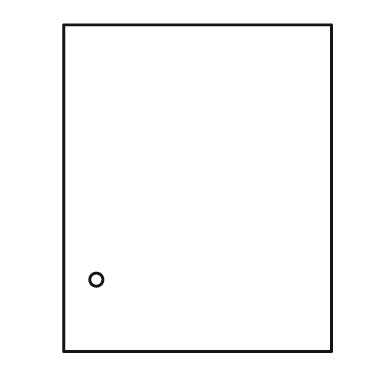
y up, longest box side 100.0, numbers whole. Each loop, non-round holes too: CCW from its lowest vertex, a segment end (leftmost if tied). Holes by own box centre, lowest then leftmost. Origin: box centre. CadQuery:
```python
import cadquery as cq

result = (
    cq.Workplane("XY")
    .moveTo(-41.0, -50.0)
    .lineTo(41.0, -50.0)
    .lineTo(41.0, 50.0)
    .lineTo(-41.0, 50.0)
    .close()
    .moveTo(-31.0, -28.0)
    .circle(2.0)
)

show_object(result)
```